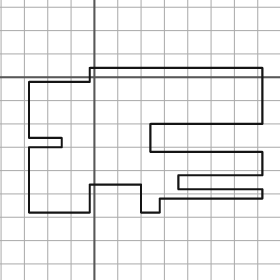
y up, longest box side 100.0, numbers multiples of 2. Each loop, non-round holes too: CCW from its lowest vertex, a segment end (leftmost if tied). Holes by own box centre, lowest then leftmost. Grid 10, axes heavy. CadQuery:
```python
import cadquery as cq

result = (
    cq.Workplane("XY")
    .moveTo(-28.0, -58.0)
    .lineTo(-2.0, -58.0)
    .lineTo(-2.0, -46.0)
    .lineTo(20.0, -46.0)
    .lineTo(20.0, -58.0)
    .lineTo(28.0, -58.0)
    .lineTo(28.0, -52.0)
    .lineTo(72.0, -52.0)
    .lineTo(72.0, -48.0)
    .lineTo(36.0, -48.0)
    .lineTo(36.0, -42.0)
    .lineTo(72.0, -42.0)
    .lineTo(72.0, -32.0)
    .lineTo(24.0, -32.0)
    .lineTo(24.0, -20.0)
    .lineTo(72.0, -20.0)
    .lineTo(72.0, 4.0)
    .lineTo(-2.0, 4.0)
    .lineTo(-2.0, -2.0)
    .lineTo(-28.0, -2.0)
    .lineTo(-28.0, -26.0)
    .lineTo(-14.0, -26.0)
    .lineTo(-14.0, -30.0)
    .lineTo(-28.0, -30.0)
    .close()
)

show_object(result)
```